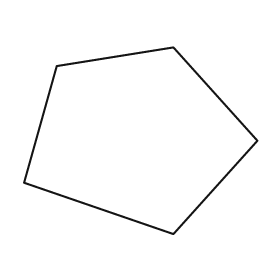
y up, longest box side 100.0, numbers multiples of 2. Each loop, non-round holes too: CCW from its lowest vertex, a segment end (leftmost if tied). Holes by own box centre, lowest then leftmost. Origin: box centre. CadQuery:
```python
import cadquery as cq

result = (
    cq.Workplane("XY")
    .moveTo(14.0, -40.0)
    .lineTo(50.0, 0.0)
    .lineTo(14.0, 40.0)
    .lineTo(-36.0, 32.0)
    .lineTo(-50.0, -18.0)
    .close()
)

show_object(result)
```